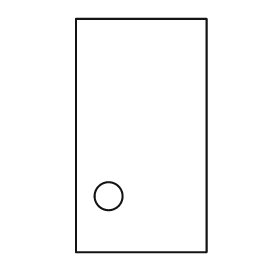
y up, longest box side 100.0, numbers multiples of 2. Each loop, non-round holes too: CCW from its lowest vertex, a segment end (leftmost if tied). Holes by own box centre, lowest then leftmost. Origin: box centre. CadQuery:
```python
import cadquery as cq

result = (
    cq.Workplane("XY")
    .moveTo(-28.0, -50.0)
    .lineTo(28.0, -50.0)
    .lineTo(28.0, 50.0)
    .lineTo(-28.0, 50.0)
    .close()
    .moveTo(-14.0, -26.0)
    .circle(6.0)
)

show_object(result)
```